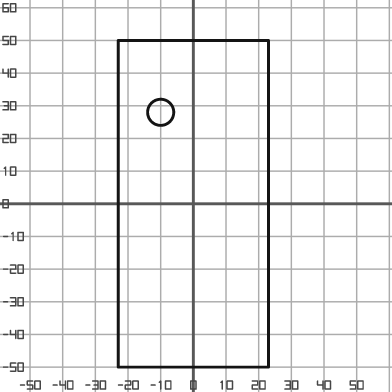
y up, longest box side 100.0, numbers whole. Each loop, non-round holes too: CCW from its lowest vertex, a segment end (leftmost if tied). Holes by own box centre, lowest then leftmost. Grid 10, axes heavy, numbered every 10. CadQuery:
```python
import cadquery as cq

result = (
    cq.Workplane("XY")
    .moveTo(-23.0, -50.0)
    .lineTo(23.0, -50.0)
    .lineTo(23.0, 50.0)
    .lineTo(-23.0, 50.0)
    .close()
    .moveTo(-10.0, 28.0)
    .circle(4.0)
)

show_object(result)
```